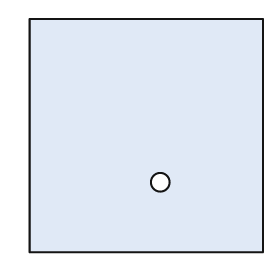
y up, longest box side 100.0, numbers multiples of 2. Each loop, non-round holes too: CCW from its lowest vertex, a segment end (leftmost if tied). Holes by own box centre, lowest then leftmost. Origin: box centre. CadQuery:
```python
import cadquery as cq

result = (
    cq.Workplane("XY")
    .moveTo(-50.0, -50.0)
    .lineTo(50.0, -50.0)
    .lineTo(50.0, 50.0)
    .lineTo(-50.0, 50.0)
    .close()
    .moveTo(6.0, -20.0)
    .circle(4.0)
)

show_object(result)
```